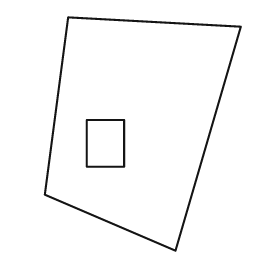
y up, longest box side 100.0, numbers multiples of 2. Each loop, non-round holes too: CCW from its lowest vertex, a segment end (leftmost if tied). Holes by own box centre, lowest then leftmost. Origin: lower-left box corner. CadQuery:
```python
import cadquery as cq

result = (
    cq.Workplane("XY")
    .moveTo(56.0, 0.0)
    .lineTo(84.0, 96.0)
    .lineTo(10.0, 100.0)
    .lineTo(0.0, 24.0)
    .close()
    .moveTo(18.0, 36.0)
    .lineTo(34.0, 36.0)
    .lineTo(34.0, 56.0)
    .lineTo(18.0, 56.0)
    .close()
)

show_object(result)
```